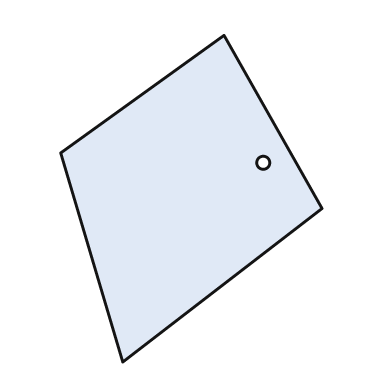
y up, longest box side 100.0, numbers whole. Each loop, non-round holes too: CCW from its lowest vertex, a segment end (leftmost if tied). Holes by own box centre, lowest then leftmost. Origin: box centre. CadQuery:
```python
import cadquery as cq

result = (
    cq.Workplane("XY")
    .moveTo(-21.0, -50.0)
    .lineTo(40.0, -3.0)
    .lineTo(10.0, 50.0)
    .lineTo(-40.0, 14.0)
    .close()
    .moveTo(22.0, 11.0)
    .circle(2.0)
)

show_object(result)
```